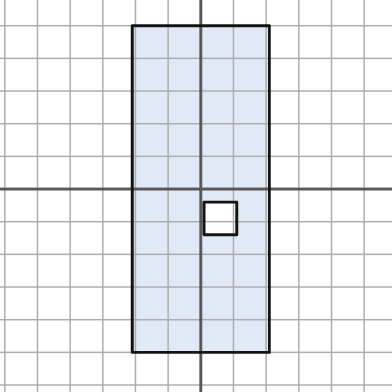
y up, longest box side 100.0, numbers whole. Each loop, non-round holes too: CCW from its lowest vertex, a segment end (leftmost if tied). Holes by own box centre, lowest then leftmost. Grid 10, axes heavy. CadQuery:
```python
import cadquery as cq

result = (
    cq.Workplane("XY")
    .moveTo(-21.0, -50.0)
    .lineTo(21.0, -50.0)
    .lineTo(21.0, 50.0)
    .lineTo(-21.0, 50.0)
    .close()
    .moveTo(1.0, -14.0)
    .lineTo(11.0, -14.0)
    .lineTo(11.0, -4.0)
    .lineTo(1.0, -4.0)
    .close()
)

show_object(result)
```